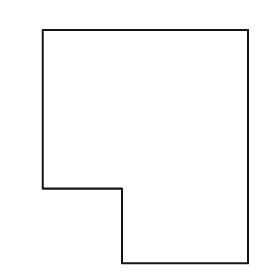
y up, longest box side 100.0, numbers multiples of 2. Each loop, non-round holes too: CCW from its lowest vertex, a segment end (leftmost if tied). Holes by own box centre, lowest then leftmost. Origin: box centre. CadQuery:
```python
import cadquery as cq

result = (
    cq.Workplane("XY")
    .moveTo(-10.0, -50.0)
    .lineTo(44.0, -50.0)
    .lineTo(44.0, 50.0)
    .lineTo(-44.0, 50.0)
    .lineTo(-44.0, -18.0)
    .lineTo(-10.0, -18.0)
    .close()
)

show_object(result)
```